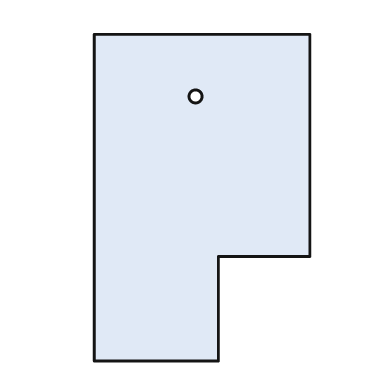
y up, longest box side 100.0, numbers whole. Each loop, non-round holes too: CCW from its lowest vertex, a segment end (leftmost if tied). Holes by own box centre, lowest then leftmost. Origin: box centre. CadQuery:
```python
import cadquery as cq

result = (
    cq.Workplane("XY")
    .moveTo(-33.0, -50.0)
    .lineTo(5.0, -50.0)
    .lineTo(5.0, -18.0)
    .lineTo(33.0, -18.0)
    .lineTo(33.0, 50.0)
    .lineTo(-33.0, 50.0)
    .close()
    .moveTo(-2.0, 31.0)
    .circle(2.0)
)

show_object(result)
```